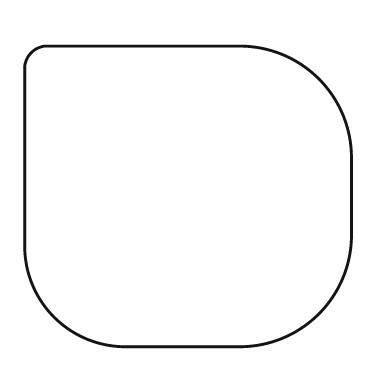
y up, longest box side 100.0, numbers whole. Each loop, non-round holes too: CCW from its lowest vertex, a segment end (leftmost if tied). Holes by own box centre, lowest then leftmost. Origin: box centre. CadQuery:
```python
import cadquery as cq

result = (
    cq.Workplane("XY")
    .moveTo(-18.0, -46.0)
    .lineTo(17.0, -46.0)
    .threePointArc((40.0, -36.0), (50.0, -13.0))
    .lineTo(50.0, 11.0)
    .threePointArc((40.0, 36.0), (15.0, 46.0))
    .lineTo(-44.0, 46.0)
    .threePointArc((-48.0, 44.0), (-50.0, 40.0))
    .lineTo(-50.0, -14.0)
    .threePointArc((-41.0, -37.0), (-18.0, -46.0))
    .close()
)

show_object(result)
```